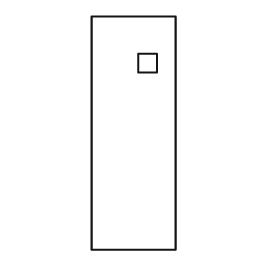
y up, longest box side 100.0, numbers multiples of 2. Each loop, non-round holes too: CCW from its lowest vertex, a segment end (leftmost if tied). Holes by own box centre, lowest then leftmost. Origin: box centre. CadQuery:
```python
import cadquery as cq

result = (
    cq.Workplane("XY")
    .moveTo(-18.0, -50.0)
    .lineTo(18.0, -50.0)
    .lineTo(18.0, 50.0)
    .lineTo(-18.0, 50.0)
    .close()
    .moveTo(2.0, 26.0)
    .lineTo(10.0, 26.0)
    .lineTo(10.0, 34.0)
    .lineTo(2.0, 34.0)
    .close()
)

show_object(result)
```